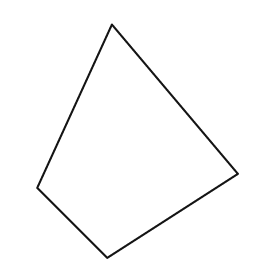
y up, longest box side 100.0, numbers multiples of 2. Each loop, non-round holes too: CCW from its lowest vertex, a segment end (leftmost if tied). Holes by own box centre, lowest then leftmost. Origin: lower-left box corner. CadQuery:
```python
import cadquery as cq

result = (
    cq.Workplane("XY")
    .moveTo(30.0, 0.0)
    .lineTo(86.0, 36.0)
    .lineTo(32.0, 100.0)
    .lineTo(0.0, 30.0)
    .close()
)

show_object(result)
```